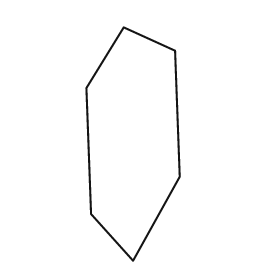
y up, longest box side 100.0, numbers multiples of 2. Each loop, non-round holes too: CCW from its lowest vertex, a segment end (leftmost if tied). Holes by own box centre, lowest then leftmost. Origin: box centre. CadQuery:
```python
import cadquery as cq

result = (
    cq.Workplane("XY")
    .moveTo(0.0, -50.0)
    .lineTo(20.0, -14.0)
    .lineTo(18.0, 40.0)
    .lineTo(-4.0, 50.0)
    .lineTo(-20.0, 24.0)
    .lineTo(-18.0, -30.0)
    .close()
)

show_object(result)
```